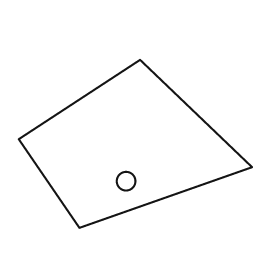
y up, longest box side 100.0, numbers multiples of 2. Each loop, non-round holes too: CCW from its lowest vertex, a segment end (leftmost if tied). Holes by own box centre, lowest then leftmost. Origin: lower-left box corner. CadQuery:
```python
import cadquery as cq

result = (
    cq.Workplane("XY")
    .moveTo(26.0, 0.0)
    .lineTo(100.0, 26.0)
    .lineTo(52.0, 72.0)
    .lineTo(0.0, 38.0)
    .close()
    .moveTo(46.0, 20.0)
    .circle(4.0)
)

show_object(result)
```